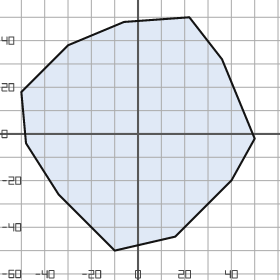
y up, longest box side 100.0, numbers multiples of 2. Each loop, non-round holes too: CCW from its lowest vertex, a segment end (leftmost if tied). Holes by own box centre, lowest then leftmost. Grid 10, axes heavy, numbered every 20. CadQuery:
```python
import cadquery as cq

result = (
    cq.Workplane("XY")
    .moveTo(-10.0, -50.0)
    .lineTo(16.0, -44.0)
    .lineTo(40.0, -20.0)
    .lineTo(50.0, -2.0)
    .lineTo(36.0, 32.0)
    .lineTo(22.0, 50.0)
    .lineTo(-6.0, 48.0)
    .lineTo(-30.0, 38.0)
    .lineTo(-50.0, 18.0)
    .lineTo(-48.0, -4.0)
    .lineTo(-34.0, -26.0)
    .close()
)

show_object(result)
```